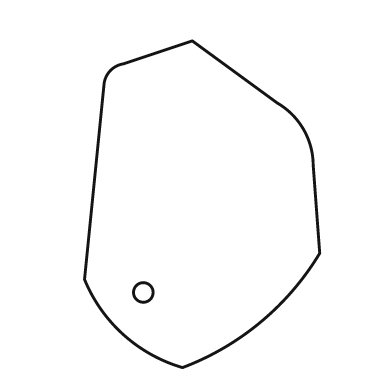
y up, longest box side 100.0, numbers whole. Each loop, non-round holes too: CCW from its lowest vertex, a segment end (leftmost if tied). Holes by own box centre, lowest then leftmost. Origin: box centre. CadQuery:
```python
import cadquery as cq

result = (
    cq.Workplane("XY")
    .moveTo(-6.0, -50.0)
    .threePointArc((18.0, -36.0), (36.0, -15.0))
    .lineTo(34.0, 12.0)
    .threePointArc((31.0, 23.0), (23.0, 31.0))
    .lineTo(-3.0, 50.0)
    .lineTo(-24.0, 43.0)
    .threePointArc((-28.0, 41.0), (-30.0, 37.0))
    .lineTo(-36.0, -23.0)
    .threePointArc((-24.0, -40.0), (-6.0, -50.0))
    .close()
    .moveTo(-18.0, -27.0)
    .circle(3.0)
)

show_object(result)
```